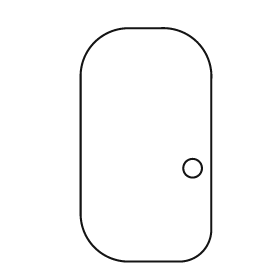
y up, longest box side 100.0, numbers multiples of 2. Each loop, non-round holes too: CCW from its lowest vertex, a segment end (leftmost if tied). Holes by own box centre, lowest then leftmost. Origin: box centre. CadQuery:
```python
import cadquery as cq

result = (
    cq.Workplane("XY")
    .moveTo(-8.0, -50.0)
    .lineTo(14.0, -50.0)
    .threePointArc((24.0, -46.0), (28.0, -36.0))
    .lineTo(28.0, 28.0)
    .threePointArc((22.0, 44.0), (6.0, 50.0))
    .lineTo(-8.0, 50.0)
    .threePointArc((-22.0, 44.0), (-28.0, 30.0))
    .lineTo(-28.0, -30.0)
    .threePointArc((-22.0, -44.0), (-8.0, -50.0))
    .close()
    .moveTo(20.0, -10.0)
    .circle(4.0)
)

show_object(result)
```